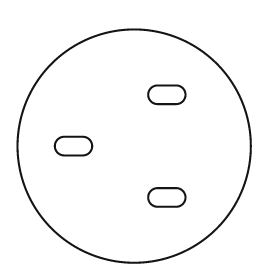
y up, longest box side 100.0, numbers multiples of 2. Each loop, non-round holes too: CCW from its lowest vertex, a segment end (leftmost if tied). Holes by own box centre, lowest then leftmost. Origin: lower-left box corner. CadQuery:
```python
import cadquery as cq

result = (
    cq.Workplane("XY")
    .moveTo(50.0, 50.0)
    .circle(50.0)
    .moveTo(60.0, 24.0)
    .lineTo(68.0, 24.0)
    .threePointArc((72.0, 28.0), (68.0, 32.0))
    .lineTo(60.0, 32.0)
    .threePointArc((56.0, 28.0), (60.0, 24.0))
    .close()
    .moveTo(20.0, 46.0)
    .lineTo(28.0, 46.0)
    .threePointArc((32.0, 50.0), (28.0, 54.0))
    .lineTo(20.0, 54.0)
    .threePointArc((16.0, 50.0), (20.0, 46.0))
    .close()
    .moveTo(60.0, 68.0)
    .lineTo(68.0, 68.0)
    .threePointArc((72.0, 72.0), (68.0, 76.0))
    .lineTo(60.0, 76.0)
    .threePointArc((56.0, 72.0), (60.0, 68.0))
    .close()
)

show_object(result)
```